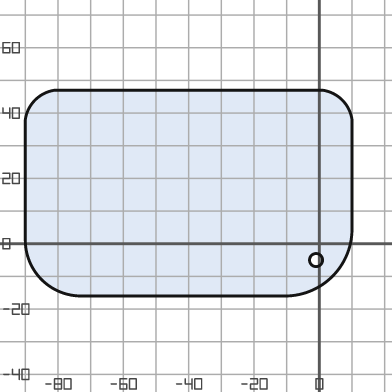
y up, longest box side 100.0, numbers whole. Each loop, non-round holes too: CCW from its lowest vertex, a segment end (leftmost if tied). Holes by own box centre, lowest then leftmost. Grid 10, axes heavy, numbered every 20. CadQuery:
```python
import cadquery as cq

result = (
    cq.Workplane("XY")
    .moveTo(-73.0, -16.0)
    .lineTo(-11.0, -16.0)
    .threePointArc((4.0, -10.0), (10.0, 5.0))
    .lineTo(10.0, 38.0)
    .threePointArc((7.0, 44.0), (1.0, 47.0))
    .lineTo(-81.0, 47.0)
    .threePointArc((-87.0, 44.0), (-90.0, 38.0))
    .lineTo(-90.0, 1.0)
    .threePointArc((-85.0, -11.0), (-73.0, -16.0))
    .close()
    .moveTo(-1.0, -5.0)
    .circle(2.0)
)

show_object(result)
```